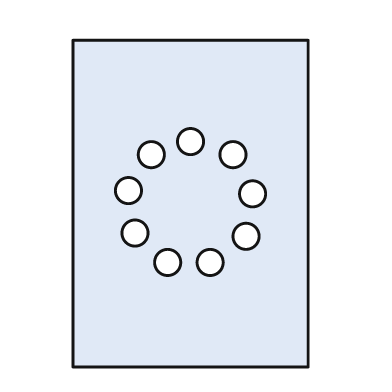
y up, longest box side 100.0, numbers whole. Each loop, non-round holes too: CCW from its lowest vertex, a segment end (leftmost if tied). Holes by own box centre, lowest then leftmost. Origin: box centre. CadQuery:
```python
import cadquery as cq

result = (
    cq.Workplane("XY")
    .moveTo(-36.0, -50.0)
    .lineTo(36.0, -50.0)
    .lineTo(36.0, 50.0)
    .lineTo(-36.0, 50.0)
    .close()
    .moveTo(-7.0, -18.0)
    .circle(4.0)
    .moveTo(6.0, -18.0)
    .circle(4.0)
    .moveTo(17.0, -10.0)
    .circle(4.0)
    .moveTo(-17.0, -9.0)
    .circle(4.0)
    .moveTo(19.0, 3.0)
    .circle(4.0)
    .moveTo(-19.0, 4.0)
    .circle(4.0)
    .moveTo(-12.0, 15.0)
    .circle(4.0)
    .moveTo(13.0, 15.0)
    .circle(4.0)
    .moveTo(0.0, 19.0)
    .circle(4.0)
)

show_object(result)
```